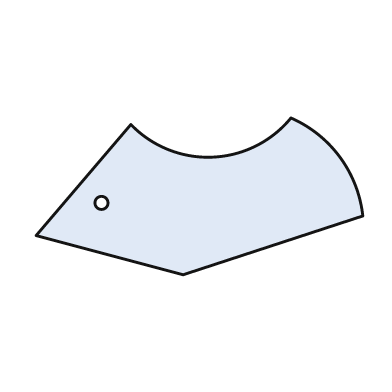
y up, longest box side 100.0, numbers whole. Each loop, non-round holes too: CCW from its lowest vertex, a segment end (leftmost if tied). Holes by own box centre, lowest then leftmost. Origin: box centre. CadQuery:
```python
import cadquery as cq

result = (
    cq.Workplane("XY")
    .moveTo(-5.0, -24.0)
    .lineTo(50.0, -6.0)
    .threePointArc((43.0, 12.0), (28.0, 24.0))
    .threePointArc((4.0, 12.0), (-21.0, 22.0))
    .lineTo(-50.0, -12.0)
    .close()
    .moveTo(-30.0, -2.0)
    .circle(2.0)
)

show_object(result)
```